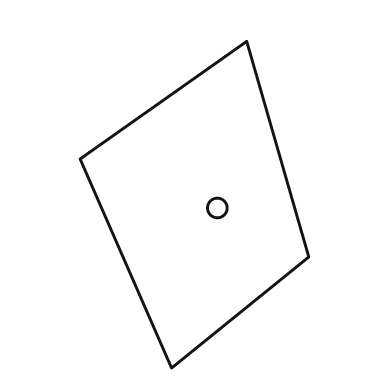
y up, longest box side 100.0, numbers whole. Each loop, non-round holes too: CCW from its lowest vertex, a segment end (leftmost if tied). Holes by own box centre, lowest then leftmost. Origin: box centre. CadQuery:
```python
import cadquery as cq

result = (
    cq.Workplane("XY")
    .moveTo(-7.0, -50.0)
    .lineTo(35.0, -16.0)
    .lineTo(16.0, 50.0)
    .lineTo(-35.0, 14.0)
    .close()
    .moveTo(7.0, -1.0)
    .circle(3.0)
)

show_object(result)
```